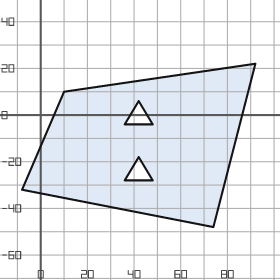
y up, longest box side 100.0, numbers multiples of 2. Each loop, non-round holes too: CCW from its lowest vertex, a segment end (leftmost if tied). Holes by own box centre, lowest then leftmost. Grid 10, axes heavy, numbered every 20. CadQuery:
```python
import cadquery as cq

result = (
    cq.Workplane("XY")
    .moveTo(74.0, -48.0)
    .lineTo(92.0, 22.0)
    .lineTo(10.0, 10.0)
    .lineTo(-8.0, -32.0)
    .close()
    .moveTo(36.0, -28.0)
    .lineTo(48.0, -28.0)
    .lineTo(42.0, -18.0)
    .close()
    .moveTo(36.0, -4.0)
    .lineTo(48.0, -4.0)
    .lineTo(42.0, 6.0)
    .close()
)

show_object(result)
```